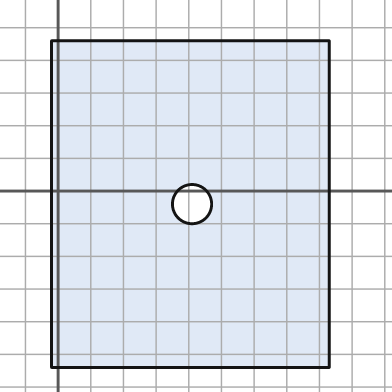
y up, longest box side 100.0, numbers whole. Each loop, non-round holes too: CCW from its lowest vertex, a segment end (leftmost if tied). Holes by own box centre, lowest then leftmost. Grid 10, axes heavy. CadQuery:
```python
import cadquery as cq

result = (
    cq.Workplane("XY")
    .moveTo(-2.0, -54.0)
    .lineTo(83.0, -54.0)
    .lineTo(83.0, 46.0)
    .lineTo(-2.0, 46.0)
    .close()
    .moveTo(41.0, -4.0)
    .circle(6.0)
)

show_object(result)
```